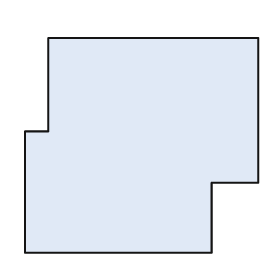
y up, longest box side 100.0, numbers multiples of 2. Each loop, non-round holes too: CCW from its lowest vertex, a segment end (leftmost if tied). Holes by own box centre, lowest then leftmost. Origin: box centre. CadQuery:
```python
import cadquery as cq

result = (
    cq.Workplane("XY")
    .moveTo(-50.0, -46.0)
    .lineTo(30.0, -46.0)
    .lineTo(30.0, -16.0)
    .lineTo(50.0, -16.0)
    .lineTo(50.0, 46.0)
    .lineTo(-40.0, 46.0)
    .lineTo(-40.0, 6.0)
    .lineTo(-50.0, 6.0)
    .close()
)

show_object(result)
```